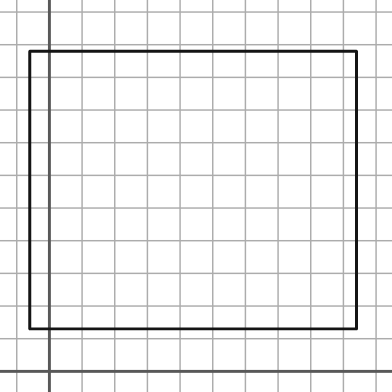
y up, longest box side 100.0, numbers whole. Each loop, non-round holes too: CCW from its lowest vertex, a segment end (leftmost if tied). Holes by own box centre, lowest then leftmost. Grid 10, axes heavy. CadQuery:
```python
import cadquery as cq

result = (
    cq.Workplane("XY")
    .moveTo(-6.0, 13.0)
    .lineTo(94.0, 13.0)
    .lineTo(94.0, 98.0)
    .lineTo(-6.0, 98.0)
    .close()
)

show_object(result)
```